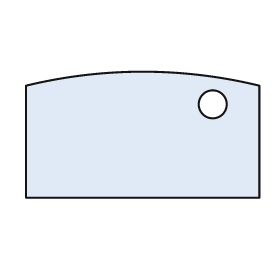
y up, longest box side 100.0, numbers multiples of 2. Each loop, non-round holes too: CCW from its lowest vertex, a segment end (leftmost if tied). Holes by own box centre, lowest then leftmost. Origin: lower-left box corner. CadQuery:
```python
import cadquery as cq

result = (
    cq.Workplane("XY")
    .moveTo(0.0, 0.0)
    .lineTo(100.0, 0.0)
    .lineTo(100.0, 48.0)
    .threePointArc((50.0, 54.0), (0.0, 48.0))
    .close()
    .moveTo(80.0, 40.0)
    .circle(6.0)
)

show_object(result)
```